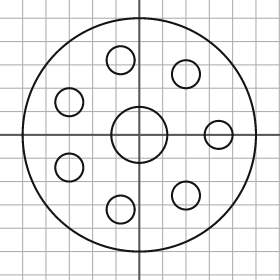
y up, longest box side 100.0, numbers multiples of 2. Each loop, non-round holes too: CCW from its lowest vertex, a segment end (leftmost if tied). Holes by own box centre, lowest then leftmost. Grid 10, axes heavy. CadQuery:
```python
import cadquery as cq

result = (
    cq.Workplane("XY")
    .moveTo(0.0, 0.0)
    .circle(50.0)
    .moveTo(-8.0, -32.0)
    .circle(6.0)
    .moveTo(20.0, -26.0)
    .circle(6.0)
    .moveTo(-30.0, -14.0)
    .circle(6.0)
    .moveTo(0.0, 0.0)
    .circle(12.0)
    .moveTo(34.0, 0.0)
    .circle(6.0)
    .moveTo(-30.0, 14.0)
    .circle(6.0)
    .moveTo(20.0, 26.0)
    .circle(6.0)
    .moveTo(-8.0, 32.0)
    .circle(6.0)
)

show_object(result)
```